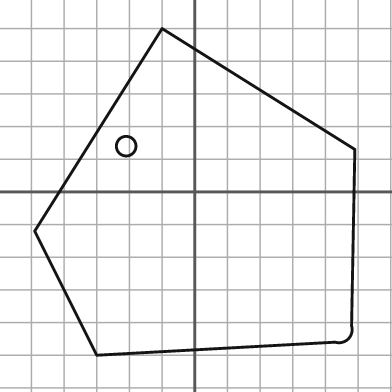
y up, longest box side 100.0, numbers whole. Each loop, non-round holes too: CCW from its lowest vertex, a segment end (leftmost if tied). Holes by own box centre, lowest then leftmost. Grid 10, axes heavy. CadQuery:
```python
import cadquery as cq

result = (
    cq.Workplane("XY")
    .moveTo(-30.0, -50.0)
    .lineTo(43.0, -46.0)
    .threePointArc((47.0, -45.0), (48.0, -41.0))
    .lineTo(49.0, 13.0)
    .lineTo(-10.0, 50.0)
    .lineTo(-49.0, -12.0)
    .close()
    .moveTo(-21.0, 14.0)
    .circle(3.0)
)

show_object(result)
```